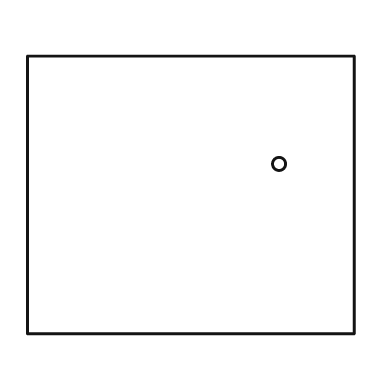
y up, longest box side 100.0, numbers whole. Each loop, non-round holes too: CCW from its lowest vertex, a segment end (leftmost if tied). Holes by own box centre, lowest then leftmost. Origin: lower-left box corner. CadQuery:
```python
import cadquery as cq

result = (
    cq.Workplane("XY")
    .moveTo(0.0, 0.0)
    .lineTo(100.0, 0.0)
    .lineTo(100.0, 85.0)
    .lineTo(0.0, 85.0)
    .close()
    .moveTo(77.0, 52.0)
    .circle(2.0)
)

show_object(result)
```